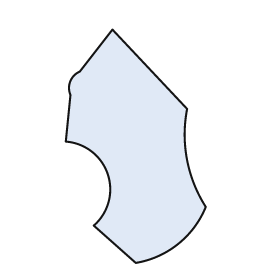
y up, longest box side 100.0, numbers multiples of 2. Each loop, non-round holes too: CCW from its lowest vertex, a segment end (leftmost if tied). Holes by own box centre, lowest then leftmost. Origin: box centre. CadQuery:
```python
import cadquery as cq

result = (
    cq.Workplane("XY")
    .moveTo(0.0, -50.0)
    .threePointArc((18.0, -42.0), (30.0, -26.0))
    .threePointArc((22.0, -6.0), (22.0, 16.0))
    .lineTo(-10.0, 50.0)
    .lineTo(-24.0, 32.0)
    .threePointArc((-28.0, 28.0), (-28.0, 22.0))
    .lineTo(-30.0, 2.0)
    .threePointArc((-12.0, -12.0), (-18.0, -34.0))
    .close()
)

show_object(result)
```